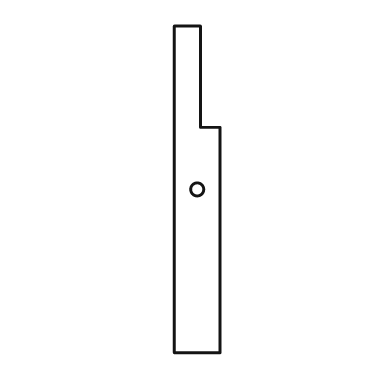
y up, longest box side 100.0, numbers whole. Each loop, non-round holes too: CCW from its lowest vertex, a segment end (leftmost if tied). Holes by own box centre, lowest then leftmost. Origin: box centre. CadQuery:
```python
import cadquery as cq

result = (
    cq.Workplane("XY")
    .moveTo(-7.0, -50.0)
    .lineTo(7.0, -50.0)
    .lineTo(7.0, 19.0)
    .lineTo(1.0, 19.0)
    .lineTo(1.0, 50.0)
    .lineTo(-7.0, 50.0)
    .close()
    .moveTo(0.0, 0.0)
    .circle(2.0)
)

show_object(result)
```